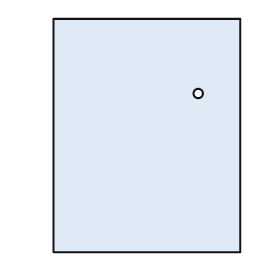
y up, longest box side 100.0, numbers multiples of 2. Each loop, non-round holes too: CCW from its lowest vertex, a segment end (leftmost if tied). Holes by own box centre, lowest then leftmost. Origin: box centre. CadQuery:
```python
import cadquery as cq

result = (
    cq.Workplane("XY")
    .moveTo(-40.0, -50.0)
    .lineTo(40.0, -50.0)
    .lineTo(40.0, 50.0)
    .lineTo(-40.0, 50.0)
    .close()
    .moveTo(22.0, 18.0)
    .circle(2.0)
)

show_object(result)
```